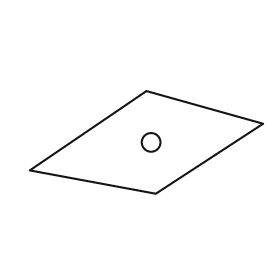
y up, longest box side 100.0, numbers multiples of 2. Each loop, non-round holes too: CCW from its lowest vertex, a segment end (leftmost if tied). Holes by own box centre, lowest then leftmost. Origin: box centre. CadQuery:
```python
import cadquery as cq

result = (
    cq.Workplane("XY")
    .moveTo(4.0, -22.0)
    .lineTo(50.0, 8.0)
    .lineTo(0.0, 22.0)
    .lineTo(-50.0, -12.0)
    .close()
    .moveTo(2.0, 0.0)
    .circle(4.0)
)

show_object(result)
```